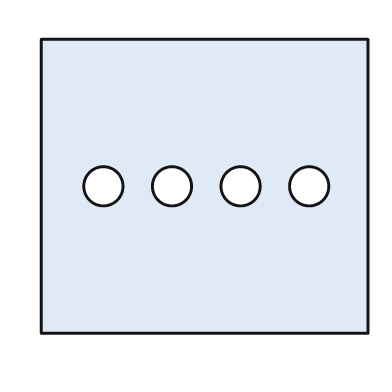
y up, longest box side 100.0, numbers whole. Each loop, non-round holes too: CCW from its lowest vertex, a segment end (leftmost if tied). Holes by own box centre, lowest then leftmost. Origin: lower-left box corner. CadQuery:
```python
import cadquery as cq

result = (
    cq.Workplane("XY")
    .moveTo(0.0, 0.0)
    .lineTo(100.0, 0.0)
    .lineTo(100.0, 90.0)
    .lineTo(0.0, 90.0)
    .close()
    .moveTo(19.0, 45.0)
    .circle(6.0)
    .moveTo(40.0, 45.0)
    .circle(6.0)
    .moveTo(61.0, 45.0)
    .circle(6.0)
    .moveTo(82.0, 45.0)
    .circle(6.0)
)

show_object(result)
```